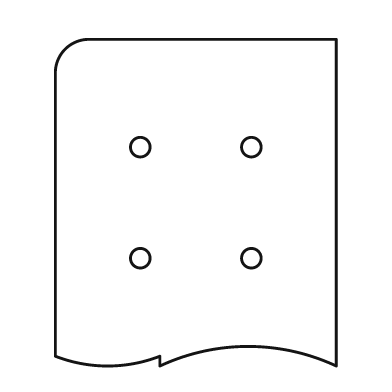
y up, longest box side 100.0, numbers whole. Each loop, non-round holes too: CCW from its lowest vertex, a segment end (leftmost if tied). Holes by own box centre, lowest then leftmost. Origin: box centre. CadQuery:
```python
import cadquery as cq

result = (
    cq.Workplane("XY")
    .moveTo(-11.0, -50.0)
    .threePointArc((16.0, -44.0), (43.0, -50.0))
    .lineTo(43.0, 50.0)
    .lineTo(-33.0, 50.0)
    .threePointArc((-40.0, 47.0), (-43.0, 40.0))
    .lineTo(-43.0, -47.0)
    .threePointArc((-27.0, -50.0), (-11.0, -47.0))
    .close()
    .moveTo(-17.0, -17.0)
    .circle(3.0)
    .moveTo(17.0, -17.0)
    .circle(3.0)
    .moveTo(-17.0, 17.0)
    .circle(3.0)
    .moveTo(17.0, 17.0)
    .circle(3.0)
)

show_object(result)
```